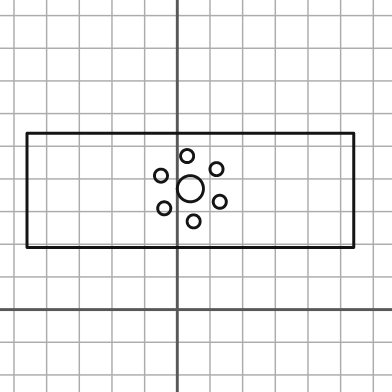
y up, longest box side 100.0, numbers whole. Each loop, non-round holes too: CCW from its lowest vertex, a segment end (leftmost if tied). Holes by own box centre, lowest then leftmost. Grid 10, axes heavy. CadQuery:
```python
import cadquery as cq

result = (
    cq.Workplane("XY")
    .moveTo(-46.0, 19.0)
    .lineTo(54.0, 19.0)
    .lineTo(54.0, 54.0)
    .lineTo(-46.0, 54.0)
    .close()
    .moveTo(5.0, 27.0)
    .circle(2.0)
    .moveTo(-4.0, 31.0)
    .circle(2.0)
    .moveTo(13.0, 33.0)
    .circle(2.0)
    .moveTo(4.0, 37.0)
    .circle(4.0)
    .moveTo(-5.0, 41.0)
    .circle(2.0)
    .moveTo(12.0, 43.0)
    .circle(2.0)
    .moveTo(3.0, 47.0)
    .circle(2.0)
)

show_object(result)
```